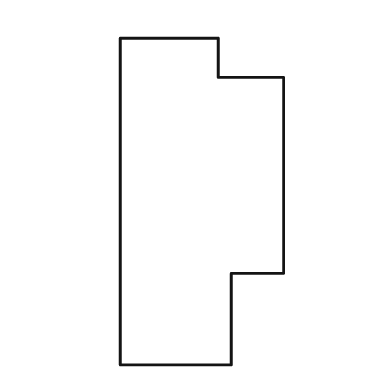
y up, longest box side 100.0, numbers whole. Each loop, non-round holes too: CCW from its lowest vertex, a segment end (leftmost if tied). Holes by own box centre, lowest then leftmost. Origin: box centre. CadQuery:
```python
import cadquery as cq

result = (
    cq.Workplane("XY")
    .moveTo(-25.0, -50.0)
    .lineTo(9.0, -50.0)
    .lineTo(9.0, -22.0)
    .lineTo(25.0, -22.0)
    .lineTo(25.0, 38.0)
    .lineTo(5.0, 38.0)
    .lineTo(5.0, 50.0)
    .lineTo(-25.0, 50.0)
    .close()
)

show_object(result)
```